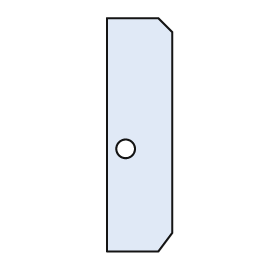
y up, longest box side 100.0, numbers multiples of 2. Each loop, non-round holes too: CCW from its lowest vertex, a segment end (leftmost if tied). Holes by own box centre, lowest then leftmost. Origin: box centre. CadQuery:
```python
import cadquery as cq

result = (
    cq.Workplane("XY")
    .moveTo(-14.0, -50.0)
    .lineTo(8.0, -50.0)
    .lineTo(14.0, -42.0)
    .lineTo(14.0, 44.0)
    .lineTo(8.0, 50.0)
    .lineTo(-14.0, 50.0)
    .close()
    .moveTo(-6.0, -6.0)
    .circle(4.0)
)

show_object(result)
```